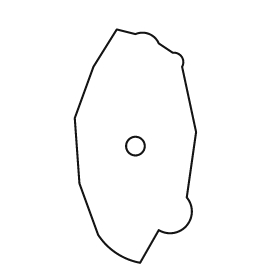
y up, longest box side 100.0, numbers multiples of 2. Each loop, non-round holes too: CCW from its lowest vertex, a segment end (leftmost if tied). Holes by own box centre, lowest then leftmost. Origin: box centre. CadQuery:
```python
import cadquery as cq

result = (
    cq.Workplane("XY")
    .moveTo(2.0, -50.0)
    .lineTo(10.0, -36.0)
    .threePointArc((22.0, -34.0), (22.0, -22.0))
    .lineTo(26.0, 6.0)
    .lineTo(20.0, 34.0)
    .threePointArc((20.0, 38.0), (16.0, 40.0))
    .lineTo(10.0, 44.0)
    .threePointArc((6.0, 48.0), (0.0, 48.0))
    .lineTo(-8.0, 50.0)
    .lineTo(-18.0, 34.0)
    .lineTo(-26.0, 12.0)
    .lineTo(-24.0, -16.0)
    .lineTo(-16.0, -38.0)
    .threePointArc((-8.0, -46.0), (2.0, -50.0))
    .close()
    .moveTo(0.0, 0.0)
    .circle(4.0)
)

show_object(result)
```